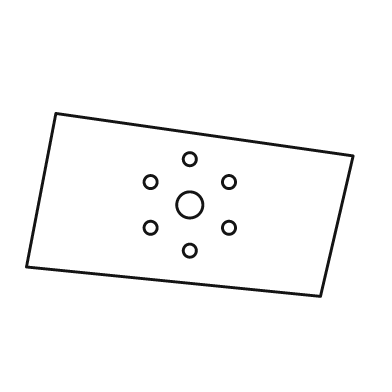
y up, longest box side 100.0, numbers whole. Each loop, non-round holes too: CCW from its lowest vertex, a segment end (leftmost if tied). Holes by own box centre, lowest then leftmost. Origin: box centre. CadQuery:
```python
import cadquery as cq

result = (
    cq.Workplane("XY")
    .moveTo(40.0, -28.0)
    .lineTo(50.0, 15.0)
    .lineTo(-41.0, 28.0)
    .lineTo(-50.0, -19.0)
    .close()
    .moveTo(0.0, -14.0)
    .circle(2.0)
    .moveTo(-12.0, -7.0)
    .circle(2.0)
    .moveTo(12.0, -7.0)
    .circle(2.0)
    .moveTo(0.0, 0.0)
    .circle(4.0)
    .moveTo(-12.0, 7.0)
    .circle(2.0)
    .moveTo(12.0, 7.0)
    .circle(2.0)
    .moveTo(0.0, 14.0)
    .circle(2.0)
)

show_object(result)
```